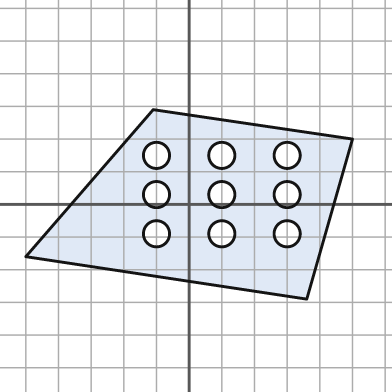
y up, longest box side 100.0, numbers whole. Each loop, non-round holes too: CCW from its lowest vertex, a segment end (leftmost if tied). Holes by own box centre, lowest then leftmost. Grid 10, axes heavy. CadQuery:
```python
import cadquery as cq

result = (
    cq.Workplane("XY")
    .moveTo(36.0, -29.0)
    .lineTo(50.0, 20.0)
    .lineTo(-11.0, 29.0)
    .lineTo(-50.0, -16.0)
    .close()
    .moveTo(-10.0, -9.0)
    .circle(4.0)
    .moveTo(10.0, -9.0)
    .circle(4.0)
    .moveTo(30.0, -9.0)
    .circle(4.0)
    .moveTo(-10.0, 3.0)
    .circle(4.0)
    .moveTo(10.0, 3.0)
    .circle(4.0)
    .moveTo(30.0, 3.0)
    .circle(4.0)
    .moveTo(-10.0, 15.0)
    .circle(4.0)
    .moveTo(10.0, 15.0)
    .circle(4.0)
    .moveTo(30.0, 15.0)
    .circle(4.0)
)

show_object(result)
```